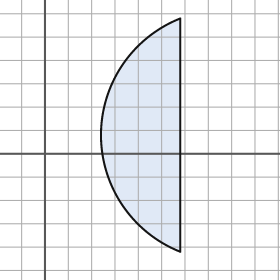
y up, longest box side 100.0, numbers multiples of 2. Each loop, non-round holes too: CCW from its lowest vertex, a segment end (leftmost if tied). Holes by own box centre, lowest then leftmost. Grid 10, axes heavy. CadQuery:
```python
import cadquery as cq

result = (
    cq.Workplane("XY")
    .moveTo(58.0, -42.0)
    .lineTo(58.0, 58.0)
    .threePointArc((24.0, 8.0), (58.0, -42.0))
    .close()
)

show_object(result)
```